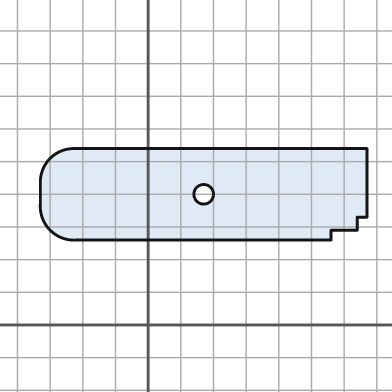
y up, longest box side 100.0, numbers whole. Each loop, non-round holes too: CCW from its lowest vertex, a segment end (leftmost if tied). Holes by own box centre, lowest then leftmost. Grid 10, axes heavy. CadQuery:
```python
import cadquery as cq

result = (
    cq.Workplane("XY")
    .moveTo(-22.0, 26.0)
    .lineTo(56.0, 26.0)
    .lineTo(56.0, 29.0)
    .lineTo(64.0, 29.0)
    .lineTo(64.0, 33.0)
    .lineTo(67.0, 33.0)
    .lineTo(67.0, 54.0)
    .lineTo(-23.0, 54.0)
    .threePointArc((-30.0, 51.0), (-33.0, 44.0))
    .lineTo(-33.0, 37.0)
    .threePointArc((-30.0, 29.0), (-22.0, 26.0))
    .close()
    .moveTo(17.0, 40.0)
    .circle(3.0)
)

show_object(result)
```